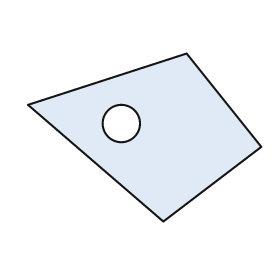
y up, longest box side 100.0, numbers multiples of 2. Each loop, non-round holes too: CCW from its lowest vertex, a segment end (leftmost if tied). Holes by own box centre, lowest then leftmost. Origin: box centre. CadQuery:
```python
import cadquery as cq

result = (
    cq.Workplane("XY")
    .moveTo(8.0, -36.0)
    .lineTo(50.0, -4.0)
    .lineTo(18.0, 36.0)
    .lineTo(-50.0, 14.0)
    .close()
    .moveTo(-10.0, 6.0)
    .circle(8.0)
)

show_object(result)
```